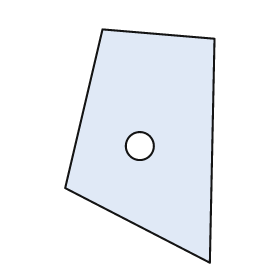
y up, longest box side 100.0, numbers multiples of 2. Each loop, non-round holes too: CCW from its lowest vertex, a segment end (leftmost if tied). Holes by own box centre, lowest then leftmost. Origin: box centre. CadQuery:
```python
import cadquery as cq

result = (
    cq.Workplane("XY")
    .moveTo(30.0, -50.0)
    .lineTo(32.0, 46.0)
    .lineTo(-16.0, 50.0)
    .lineTo(-32.0, -18.0)
    .close()
    .moveTo(0.0, 0.0)
    .circle(6.0)
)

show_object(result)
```